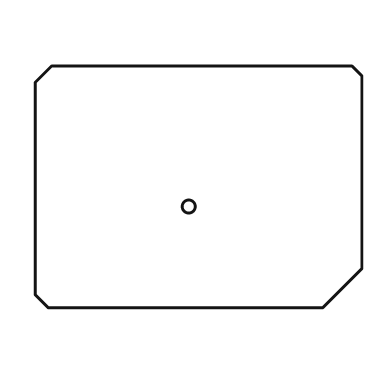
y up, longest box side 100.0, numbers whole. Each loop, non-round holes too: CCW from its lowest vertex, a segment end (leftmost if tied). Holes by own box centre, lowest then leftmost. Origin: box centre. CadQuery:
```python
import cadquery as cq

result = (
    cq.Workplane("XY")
    .moveTo(-46.0, -37.0)
    .lineTo(38.0, -37.0)
    .lineTo(50.0, -25.0)
    .lineTo(50.0, 34.0)
    .lineTo(47.0, 37.0)
    .lineTo(-45.0, 37.0)
    .lineTo(-50.0, 32.0)
    .lineTo(-50.0, -33.0)
    .close()
    .moveTo(-3.0, -6.0)
    .circle(2.0)
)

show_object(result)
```